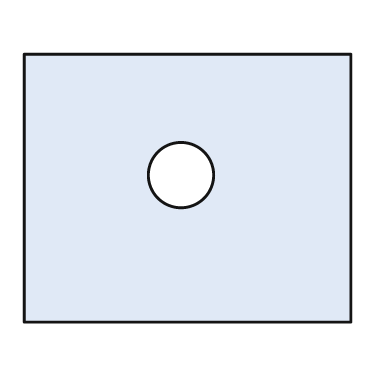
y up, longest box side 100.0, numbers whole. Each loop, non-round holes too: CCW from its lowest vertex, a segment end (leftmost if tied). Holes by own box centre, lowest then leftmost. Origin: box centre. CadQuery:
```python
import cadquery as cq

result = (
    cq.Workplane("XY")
    .moveTo(-50.0, -41.0)
    .lineTo(50.0, -41.0)
    .lineTo(50.0, 41.0)
    .lineTo(-50.0, 41.0)
    .close()
    .moveTo(-2.0, 4.0)
    .circle(10.0)
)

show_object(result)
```